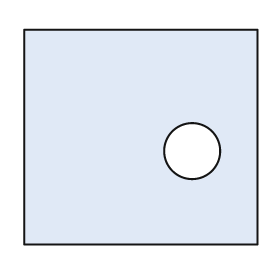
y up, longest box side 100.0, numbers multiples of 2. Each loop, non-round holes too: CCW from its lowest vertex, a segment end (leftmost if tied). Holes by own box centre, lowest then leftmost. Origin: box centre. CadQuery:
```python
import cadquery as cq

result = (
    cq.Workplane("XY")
    .moveTo(-50.0, -46.0)
    .lineTo(50.0, -46.0)
    .lineTo(50.0, 46.0)
    .lineTo(-50.0, 46.0)
    .close()
    .moveTo(22.0, -6.0)
    .circle(12.0)
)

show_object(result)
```